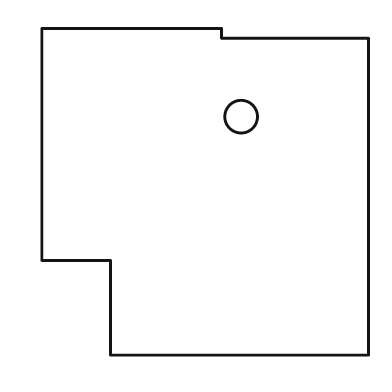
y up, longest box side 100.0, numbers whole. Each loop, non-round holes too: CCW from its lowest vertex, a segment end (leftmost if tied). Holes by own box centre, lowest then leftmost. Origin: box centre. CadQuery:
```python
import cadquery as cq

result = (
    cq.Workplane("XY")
    .moveTo(-29.0, -50.0)
    .lineTo(50.0, -50.0)
    .lineTo(50.0, 47.0)
    .lineTo(5.0, 47.0)
    .lineTo(5.0, 50.0)
    .lineTo(-50.0, 50.0)
    .lineTo(-50.0, -21.0)
    .lineTo(-29.0, -21.0)
    .close()
    .moveTo(11.0, 23.0)
    .circle(5.0)
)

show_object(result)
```